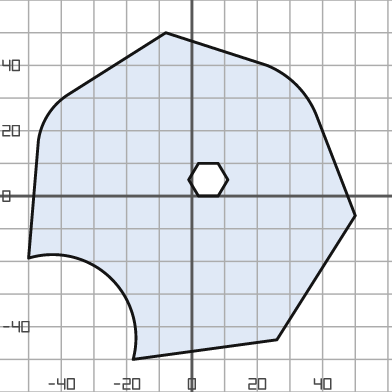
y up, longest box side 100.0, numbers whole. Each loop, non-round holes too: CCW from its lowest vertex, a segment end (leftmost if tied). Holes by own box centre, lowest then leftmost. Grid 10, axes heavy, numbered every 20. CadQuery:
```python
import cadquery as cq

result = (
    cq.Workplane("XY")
    .moveTo(-18.0, -50.0)
    .lineTo(26.0, -44.0)
    .lineTo(50.0, -6.0)
    .lineTo(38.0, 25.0)
    .threePointArc((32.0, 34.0), (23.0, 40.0))
    .lineTo(-8.0, 50.0)
    .lineTo(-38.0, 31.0)
    .threePointArc((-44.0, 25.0), (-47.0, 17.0))
    .lineTo(-50.0, -19.0)
    .threePointArc((-25.0, -25.0), (-18.0, -50.0))
    .close()
    .moveTo(2.0, 0.0)
    .lineTo(8.0, 0.0)
    .lineTo(11.0, 5.0)
    .lineTo(8.0, 10.0)
    .lineTo(2.0, 10.0)
    .lineTo(-1.0, 5.0)
    .close()
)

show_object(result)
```